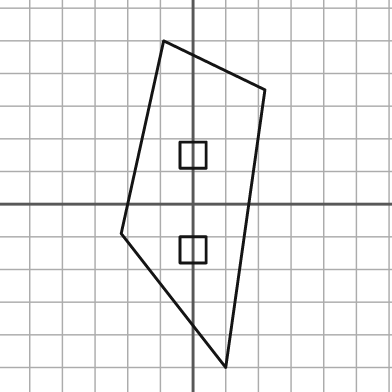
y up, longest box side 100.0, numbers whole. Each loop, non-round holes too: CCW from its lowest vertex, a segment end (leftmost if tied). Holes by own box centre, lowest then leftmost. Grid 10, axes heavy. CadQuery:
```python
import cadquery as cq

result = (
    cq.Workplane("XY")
    .moveTo(10.0, -50.0)
    .lineTo(22.0, 35.0)
    .lineTo(-9.0, 50.0)
    .lineTo(-22.0, -9.0)
    .close()
    .moveTo(-4.0, -18.0)
    .lineTo(4.0, -18.0)
    .lineTo(4.0, -10.0)
    .lineTo(-4.0, -10.0)
    .close()
    .moveTo(-4.0, 11.0)
    .lineTo(4.0, 11.0)
    .lineTo(4.0, 19.0)
    .lineTo(-4.0, 19.0)
    .close()
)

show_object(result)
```